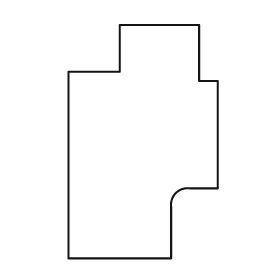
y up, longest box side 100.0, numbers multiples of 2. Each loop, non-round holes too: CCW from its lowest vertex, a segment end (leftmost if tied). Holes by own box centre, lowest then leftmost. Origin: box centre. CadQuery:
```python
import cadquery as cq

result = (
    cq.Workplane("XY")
    .moveTo(-32.0, -50.0)
    .lineTo(12.0, -50.0)
    .lineTo(12.0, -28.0)
    .threePointArc((14.0, -22.0), (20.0, -20.0))
    .lineTo(32.0, -20.0)
    .lineTo(32.0, 26.0)
    .lineTo(24.0, 26.0)
    .lineTo(24.0, 50.0)
    .lineTo(-10.0, 50.0)
    .lineTo(-10.0, 30.0)
    .lineTo(-32.0, 30.0)
    .close()
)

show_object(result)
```